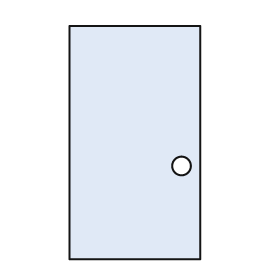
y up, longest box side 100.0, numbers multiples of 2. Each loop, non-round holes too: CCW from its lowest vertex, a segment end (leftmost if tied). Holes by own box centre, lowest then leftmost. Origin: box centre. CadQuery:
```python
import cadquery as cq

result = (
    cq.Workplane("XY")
    .moveTo(-28.0, -50.0)
    .lineTo(28.0, -50.0)
    .lineTo(28.0, 50.0)
    .lineTo(-28.0, 50.0)
    .close()
    .moveTo(20.0, -10.0)
    .circle(4.0)
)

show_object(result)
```